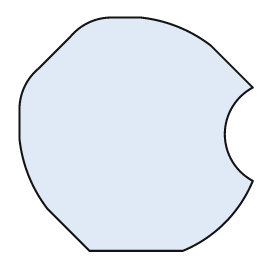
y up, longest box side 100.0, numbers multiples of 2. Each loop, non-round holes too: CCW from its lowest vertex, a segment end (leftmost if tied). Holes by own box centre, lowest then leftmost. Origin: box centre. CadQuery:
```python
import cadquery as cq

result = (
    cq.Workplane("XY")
    .moveTo(-20.0, -50.0)
    .lineTo(20.0, -50.0)
    .threePointArc((38.0, -38.0), (50.0, -20.0))
    .threePointArc((38.0, 0.0), (50.0, 20.0))
    .lineTo(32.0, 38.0)
    .threePointArc((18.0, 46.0), (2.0, 50.0))
    .lineTo(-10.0, 50.0)
    .threePointArc((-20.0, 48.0), (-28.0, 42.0))
    .lineTo(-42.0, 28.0)
    .threePointArc((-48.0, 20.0), (-50.0, 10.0))
    .lineTo(-50.0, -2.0)
    .threePointArc((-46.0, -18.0), (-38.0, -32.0))
    .close()
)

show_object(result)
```